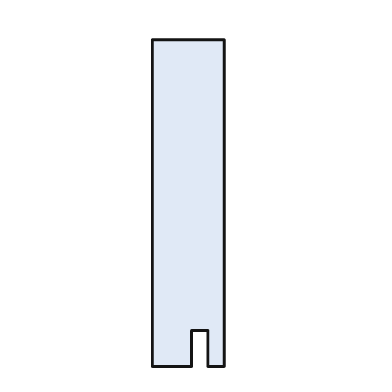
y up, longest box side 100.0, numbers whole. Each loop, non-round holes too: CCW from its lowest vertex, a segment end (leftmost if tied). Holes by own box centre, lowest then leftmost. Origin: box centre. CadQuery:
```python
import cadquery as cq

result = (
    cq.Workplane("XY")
    .moveTo(-11.0, -50.0)
    .lineTo(1.0, -50.0)
    .lineTo(1.0, -39.0)
    .lineTo(6.0, -39.0)
    .lineTo(6.0, -50.0)
    .lineTo(11.0, -50.0)
    .lineTo(11.0, 50.0)
    .lineTo(-11.0, 50.0)
    .close()
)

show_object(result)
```